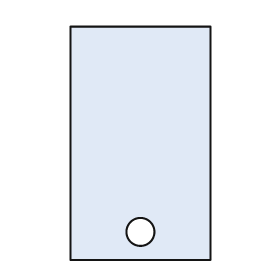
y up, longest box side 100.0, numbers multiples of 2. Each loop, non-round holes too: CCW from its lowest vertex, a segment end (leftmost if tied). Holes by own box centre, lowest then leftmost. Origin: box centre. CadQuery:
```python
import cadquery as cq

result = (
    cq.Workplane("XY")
    .moveTo(-30.0, -50.0)
    .lineTo(30.0, -50.0)
    .lineTo(30.0, 50.0)
    .lineTo(-30.0, 50.0)
    .close()
    .moveTo(0.0, -38.0)
    .circle(6.0)
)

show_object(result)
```